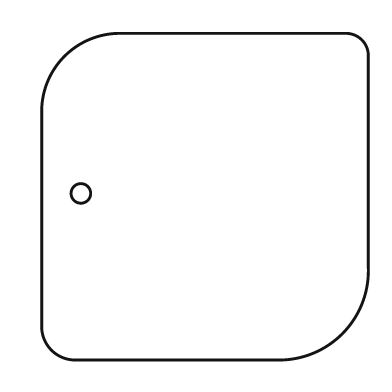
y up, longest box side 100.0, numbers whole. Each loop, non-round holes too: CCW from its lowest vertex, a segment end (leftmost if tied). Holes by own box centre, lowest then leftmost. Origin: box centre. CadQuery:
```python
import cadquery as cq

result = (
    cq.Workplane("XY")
    .moveTo(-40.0, -50.0)
    .lineTo(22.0, -50.0)
    .threePointArc((42.0, -42.0), (50.0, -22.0))
    .lineTo(50.0, 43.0)
    .threePointArc((48.0, 48.0), (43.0, 50.0))
    .lineTo(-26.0, 50.0)
    .threePointArc((-43.0, 43.0), (-50.0, 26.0))
    .lineTo(-50.0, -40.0)
    .threePointArc((-47.0, -47.0), (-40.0, -50.0))
    .close()
    .moveTo(-38.0, 1.0)
    .circle(3.0)
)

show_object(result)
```